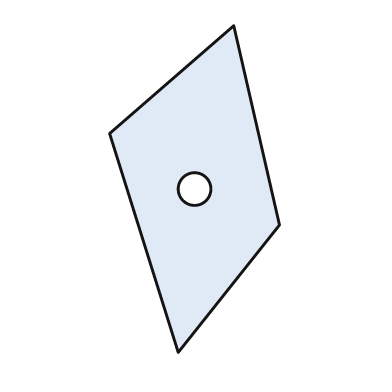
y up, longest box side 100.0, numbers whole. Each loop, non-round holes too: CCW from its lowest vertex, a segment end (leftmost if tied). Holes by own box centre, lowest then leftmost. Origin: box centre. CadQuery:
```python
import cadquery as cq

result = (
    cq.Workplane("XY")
    .moveTo(-5.0, -50.0)
    .lineTo(26.0, -11.0)
    .lineTo(12.0, 50.0)
    .lineTo(-26.0, 17.0)
    .close()
    .moveTo(0.0, 0.0)
    .circle(5.0)
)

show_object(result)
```